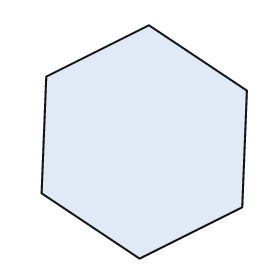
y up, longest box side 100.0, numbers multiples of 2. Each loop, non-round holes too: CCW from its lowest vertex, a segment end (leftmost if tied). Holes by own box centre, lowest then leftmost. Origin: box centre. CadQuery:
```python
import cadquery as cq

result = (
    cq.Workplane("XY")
    .moveTo(-2.0, -50.0)
    .lineTo(42.0, -28.0)
    .lineTo(44.0, 22.0)
    .lineTo(2.0, 50.0)
    .lineTo(-42.0, 28.0)
    .lineTo(-44.0, -22.0)
    .close()
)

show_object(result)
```